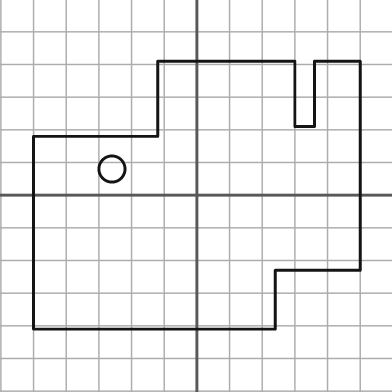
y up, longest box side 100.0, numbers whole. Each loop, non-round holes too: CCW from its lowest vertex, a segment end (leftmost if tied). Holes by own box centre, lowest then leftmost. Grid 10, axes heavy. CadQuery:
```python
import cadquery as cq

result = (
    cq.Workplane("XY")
    .moveTo(-50.0, -41.0)
    .lineTo(24.0, -41.0)
    .lineTo(24.0, -23.0)
    .lineTo(50.0, -23.0)
    .lineTo(50.0, 41.0)
    .lineTo(36.0, 41.0)
    .lineTo(36.0, 21.0)
    .lineTo(30.0, 21.0)
    .lineTo(30.0, 41.0)
    .lineTo(-12.0, 41.0)
    .lineTo(-12.0, 18.0)
    .lineTo(-50.0, 18.0)
    .close()
    .moveTo(-26.0, 8.0)
    .circle(4.0)
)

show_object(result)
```